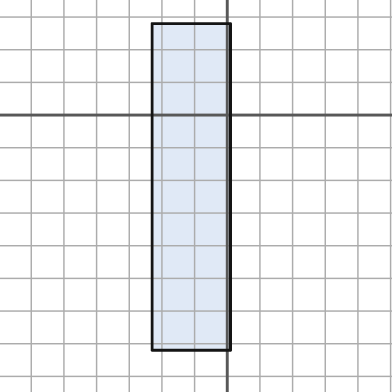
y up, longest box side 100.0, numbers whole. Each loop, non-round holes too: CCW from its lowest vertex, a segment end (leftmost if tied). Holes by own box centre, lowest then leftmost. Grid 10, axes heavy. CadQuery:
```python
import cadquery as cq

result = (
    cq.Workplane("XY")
    .moveTo(-23.0, -72.0)
    .lineTo(1.0, -72.0)
    .lineTo(1.0, 28.0)
    .lineTo(-23.0, 28.0)
    .close()
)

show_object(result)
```